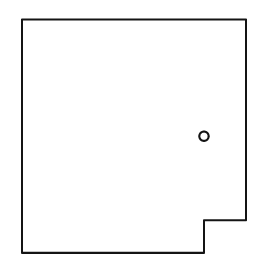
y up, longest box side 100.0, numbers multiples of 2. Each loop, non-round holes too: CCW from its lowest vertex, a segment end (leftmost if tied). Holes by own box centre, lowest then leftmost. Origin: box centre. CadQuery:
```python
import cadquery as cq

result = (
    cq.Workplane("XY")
    .moveTo(-48.0, -50.0)
    .lineTo(30.0, -50.0)
    .lineTo(30.0, -36.0)
    .lineTo(48.0, -36.0)
    .lineTo(48.0, 50.0)
    .lineTo(-48.0, 50.0)
    .close()
    .moveTo(30.0, 0.0)
    .circle(2.0)
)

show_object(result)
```